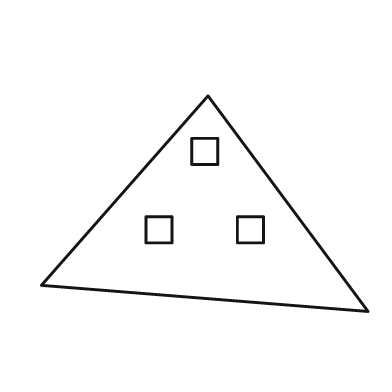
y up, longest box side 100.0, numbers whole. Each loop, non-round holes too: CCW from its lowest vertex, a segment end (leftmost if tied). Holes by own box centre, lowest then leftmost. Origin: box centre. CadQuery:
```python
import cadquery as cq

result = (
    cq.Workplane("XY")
    .moveTo(50.0, -33.0)
    .lineTo(1.0, 33.0)
    .lineTo(-50.0, -25.0)
    .close()
    .moveTo(-18.0, -12.0)
    .lineTo(-10.0, -12.0)
    .lineTo(-10.0, -4.0)
    .lineTo(-18.0, -4.0)
    .close()
    .moveTo(10.0, -12.0)
    .lineTo(18.0, -12.0)
    .lineTo(18.0, -4.0)
    .lineTo(10.0, -4.0)
    .close()
    .moveTo(-4.0, 12.0)
    .lineTo(4.0, 12.0)
    .lineTo(4.0, 20.0)
    .lineTo(-4.0, 20.0)
    .close()
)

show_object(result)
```